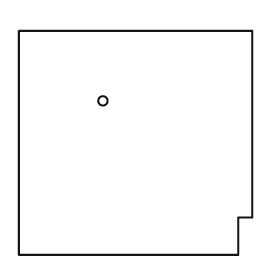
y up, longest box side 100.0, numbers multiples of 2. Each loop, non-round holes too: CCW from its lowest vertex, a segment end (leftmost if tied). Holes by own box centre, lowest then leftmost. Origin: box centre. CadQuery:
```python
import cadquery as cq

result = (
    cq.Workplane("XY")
    .moveTo(-50.0, -48.0)
    .lineTo(44.0, -48.0)
    .lineTo(44.0, -32.0)
    .lineTo(50.0, -32.0)
    .lineTo(50.0, 48.0)
    .lineTo(-50.0, 48.0)
    .close()
    .moveTo(-14.0, 18.0)
    .circle(2.0)
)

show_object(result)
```